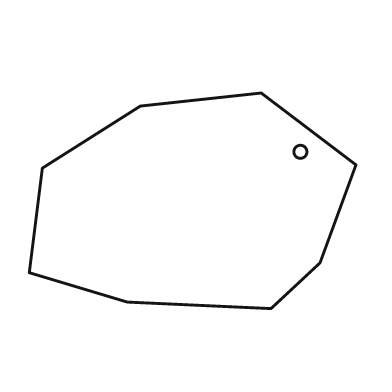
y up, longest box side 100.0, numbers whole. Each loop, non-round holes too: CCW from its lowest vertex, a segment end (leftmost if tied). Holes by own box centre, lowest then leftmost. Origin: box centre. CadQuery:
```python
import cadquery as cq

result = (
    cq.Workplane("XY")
    .moveTo(24.0, -33.0)
    .lineTo(39.0, -19.0)
    .lineTo(50.0, 11.0)
    .lineTo(21.0, 33.0)
    .lineTo(-16.0, 29.0)
    .lineTo(-46.0, 10.0)
    .lineTo(-50.0, -22.0)
    .lineTo(-20.0, -31.0)
    .close()
    .moveTo(33.0, 15.0)
    .circle(2.0)
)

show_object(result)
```